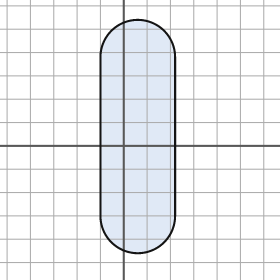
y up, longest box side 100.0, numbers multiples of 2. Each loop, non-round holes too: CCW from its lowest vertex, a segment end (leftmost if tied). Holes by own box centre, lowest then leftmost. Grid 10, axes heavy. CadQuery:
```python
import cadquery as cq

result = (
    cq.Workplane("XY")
    .moveTo(-10.0, -30.0)
    .threePointArc((6.0, -46.0), (22.0, -30.0))
    .lineTo(22.0, 38.0)
    .threePointArc((6.0, 54.0), (-10.0, 38.0))
    .close()
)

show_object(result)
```